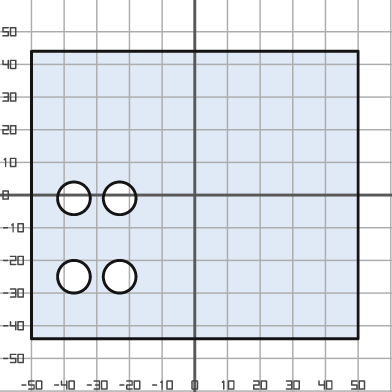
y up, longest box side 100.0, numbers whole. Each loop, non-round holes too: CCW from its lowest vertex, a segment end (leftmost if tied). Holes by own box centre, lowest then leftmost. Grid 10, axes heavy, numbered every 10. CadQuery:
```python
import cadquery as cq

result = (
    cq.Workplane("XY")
    .moveTo(-50.0, -44.0)
    .lineTo(50.0, -44.0)
    .lineTo(50.0, 44.0)
    .lineTo(-50.0, 44.0)
    .close()
    .moveTo(-37.0, -25.0)
    .circle(5.0)
    .moveTo(-23.0, -25.0)
    .circle(5.0)
    .moveTo(-37.0, -1.0)
    .circle(5.0)
    .moveTo(-23.0, -1.0)
    .circle(5.0)
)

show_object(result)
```